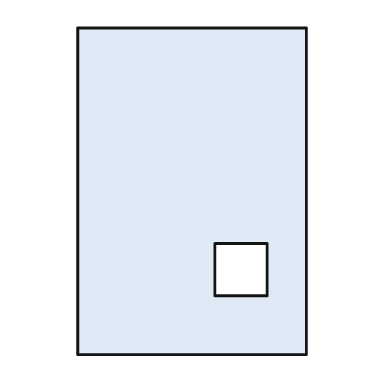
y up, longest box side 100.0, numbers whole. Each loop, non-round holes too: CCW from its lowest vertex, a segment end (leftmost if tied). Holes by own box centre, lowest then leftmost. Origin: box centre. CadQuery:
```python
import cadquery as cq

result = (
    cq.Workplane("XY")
    .moveTo(-35.0, -50.0)
    .lineTo(35.0, -50.0)
    .lineTo(35.0, 50.0)
    .lineTo(-35.0, 50.0)
    .close()
    .moveTo(7.0, -32.0)
    .lineTo(23.0, -32.0)
    .lineTo(23.0, -16.0)
    .lineTo(7.0, -16.0)
    .close()
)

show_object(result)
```